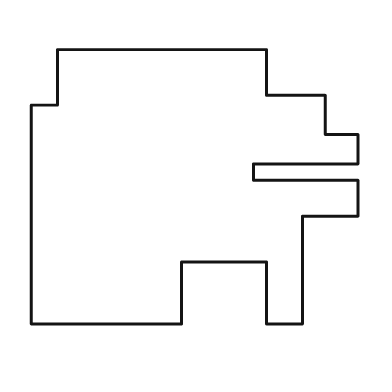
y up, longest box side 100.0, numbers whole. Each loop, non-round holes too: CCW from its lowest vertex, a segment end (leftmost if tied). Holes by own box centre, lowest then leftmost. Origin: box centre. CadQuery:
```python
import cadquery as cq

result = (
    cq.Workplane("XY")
    .moveTo(-50.0, -42.0)
    .lineTo(-4.0, -42.0)
    .lineTo(-4.0, -23.0)
    .lineTo(22.0, -23.0)
    .lineTo(22.0, -42.0)
    .lineTo(33.0, -42.0)
    .lineTo(33.0, -9.0)
    .lineTo(50.0, -9.0)
    .lineTo(50.0, 2.0)
    .lineTo(18.0, 2.0)
    .lineTo(18.0, 7.0)
    .lineTo(50.0, 7.0)
    .lineTo(50.0, 16.0)
    .lineTo(40.0, 16.0)
    .lineTo(40.0, 28.0)
    .lineTo(22.0, 28.0)
    .lineTo(22.0, 42.0)
    .lineTo(-42.0, 42.0)
    .lineTo(-42.0, 25.0)
    .lineTo(-50.0, 25.0)
    .close()
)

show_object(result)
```